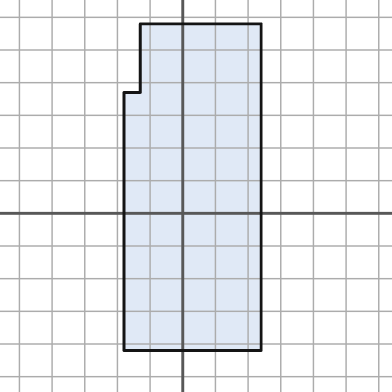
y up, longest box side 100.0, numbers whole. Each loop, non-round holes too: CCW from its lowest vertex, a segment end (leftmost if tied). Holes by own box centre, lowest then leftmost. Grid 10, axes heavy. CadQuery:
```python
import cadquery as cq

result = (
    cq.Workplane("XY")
    .moveTo(-18.0, -42.0)
    .lineTo(24.0, -42.0)
    .lineTo(24.0, 58.0)
    .lineTo(-13.0, 58.0)
    .lineTo(-13.0, 37.0)
    .lineTo(-18.0, 37.0)
    .close()
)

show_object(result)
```